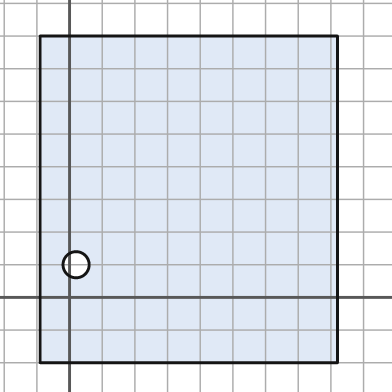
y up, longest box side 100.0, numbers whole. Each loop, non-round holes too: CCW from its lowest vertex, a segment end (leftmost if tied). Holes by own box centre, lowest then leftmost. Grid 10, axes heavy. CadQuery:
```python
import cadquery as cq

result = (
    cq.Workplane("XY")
    .moveTo(-9.0, -20.0)
    .lineTo(82.0, -20.0)
    .lineTo(82.0, 80.0)
    .lineTo(-9.0, 80.0)
    .close()
    .moveTo(2.0, 10.0)
    .circle(4.0)
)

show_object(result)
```